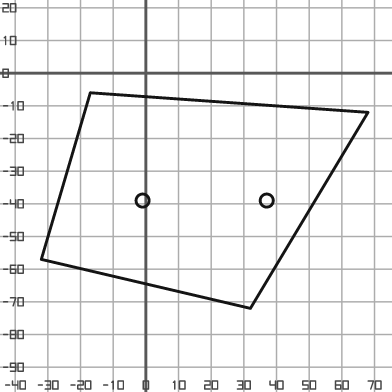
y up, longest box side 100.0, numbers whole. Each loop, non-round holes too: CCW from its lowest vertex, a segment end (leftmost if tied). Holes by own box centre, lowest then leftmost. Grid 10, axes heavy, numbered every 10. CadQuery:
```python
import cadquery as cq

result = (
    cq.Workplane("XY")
    .moveTo(32.0, -72.0)
    .lineTo(68.0, -12.0)
    .lineTo(-17.0, -6.0)
    .lineTo(-32.0, -57.0)
    .close()
    .moveTo(-1.0, -39.0)
    .circle(2.0)
    .moveTo(37.0, -39.0)
    .circle(2.0)
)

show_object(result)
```